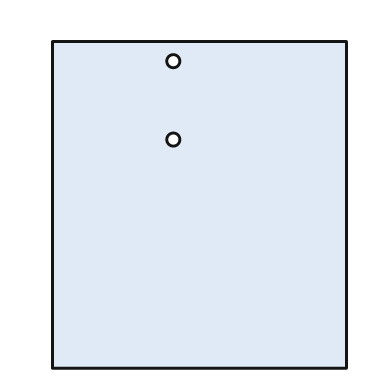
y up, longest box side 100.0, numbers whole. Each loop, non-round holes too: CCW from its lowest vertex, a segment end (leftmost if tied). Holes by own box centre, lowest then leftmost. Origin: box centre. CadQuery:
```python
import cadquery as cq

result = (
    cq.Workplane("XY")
    .moveTo(-45.0, -50.0)
    .lineTo(45.0, -50.0)
    .lineTo(45.0, 50.0)
    .lineTo(-45.0, 50.0)
    .close()
    .moveTo(-8.0, 20.0)
    .circle(2.0)
    .moveTo(-8.0, 44.0)
    .circle(2.0)
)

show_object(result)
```